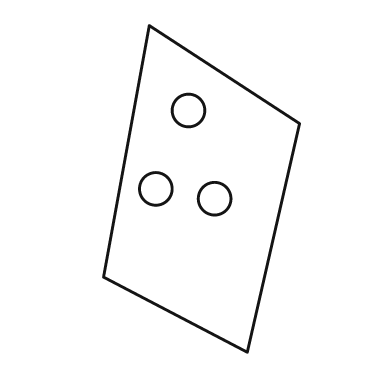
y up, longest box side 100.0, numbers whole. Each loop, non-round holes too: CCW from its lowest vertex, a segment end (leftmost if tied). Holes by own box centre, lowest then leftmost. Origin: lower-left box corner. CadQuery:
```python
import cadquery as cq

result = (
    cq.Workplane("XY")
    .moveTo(44.0, 0.0)
    .lineTo(60.0, 70.0)
    .lineTo(14.0, 100.0)
    .lineTo(0.0, 23.0)
    .close()
    .moveTo(34.0, 47.0)
    .circle(5.0)
    .moveTo(16.0, 50.0)
    .circle(5.0)
    .moveTo(26.0, 74.0)
    .circle(5.0)
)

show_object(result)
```